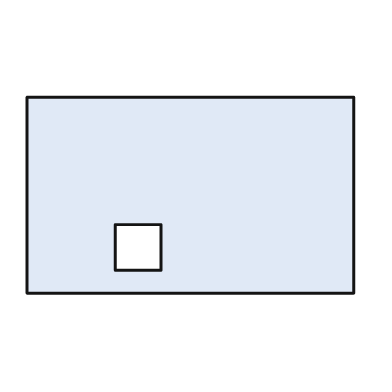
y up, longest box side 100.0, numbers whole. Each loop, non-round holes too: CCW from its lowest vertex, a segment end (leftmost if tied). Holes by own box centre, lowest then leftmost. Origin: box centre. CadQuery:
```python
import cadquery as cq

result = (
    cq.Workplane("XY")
    .moveTo(-50.0, -30.0)
    .lineTo(50.0, -30.0)
    .lineTo(50.0, 30.0)
    .lineTo(-50.0, 30.0)
    .close()
    .moveTo(-23.0, -23.0)
    .lineTo(-9.0, -23.0)
    .lineTo(-9.0, -9.0)
    .lineTo(-23.0, -9.0)
    .close()
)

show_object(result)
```